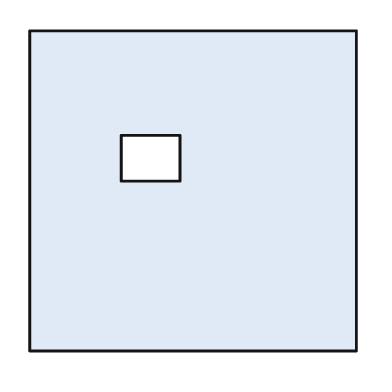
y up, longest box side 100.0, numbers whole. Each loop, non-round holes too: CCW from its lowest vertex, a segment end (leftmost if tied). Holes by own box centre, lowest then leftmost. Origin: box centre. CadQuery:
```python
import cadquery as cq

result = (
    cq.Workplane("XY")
    .moveTo(-50.0, -49.0)
    .lineTo(50.0, -49.0)
    .lineTo(50.0, 49.0)
    .lineTo(-50.0, 49.0)
    .close()
    .moveTo(-22.0, 3.0)
    .lineTo(-4.0, 3.0)
    .lineTo(-4.0, 17.0)
    .lineTo(-22.0, 17.0)
    .close()
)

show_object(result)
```